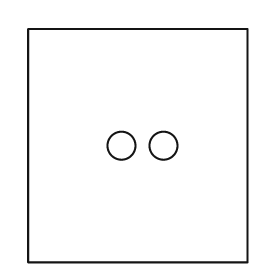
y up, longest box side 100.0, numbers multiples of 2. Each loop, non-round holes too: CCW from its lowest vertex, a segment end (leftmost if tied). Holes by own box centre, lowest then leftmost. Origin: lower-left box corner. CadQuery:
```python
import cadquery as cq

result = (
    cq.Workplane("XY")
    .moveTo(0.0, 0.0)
    .lineTo(94.0, 0.0)
    .lineTo(94.0, 100.0)
    .lineTo(0.0, 100.0)
    .close()
    .moveTo(40.0, 50.0)
    .circle(6.0)
    .moveTo(58.0, 50.0)
    .circle(6.0)
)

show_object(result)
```